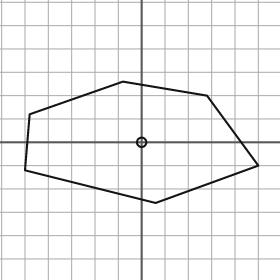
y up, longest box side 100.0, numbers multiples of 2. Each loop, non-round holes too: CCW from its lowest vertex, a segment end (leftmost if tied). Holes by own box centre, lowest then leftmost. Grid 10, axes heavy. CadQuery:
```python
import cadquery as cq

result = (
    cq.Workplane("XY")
    .moveTo(6.0, -26.0)
    .lineTo(50.0, -10.0)
    .lineTo(28.0, 20.0)
    .lineTo(-8.0, 26.0)
    .lineTo(-48.0, 12.0)
    .lineTo(-50.0, -12.0)
    .close()
    .moveTo(0.0, 0.0)
    .circle(2.0)
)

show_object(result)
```